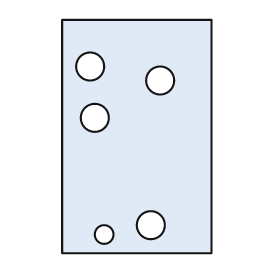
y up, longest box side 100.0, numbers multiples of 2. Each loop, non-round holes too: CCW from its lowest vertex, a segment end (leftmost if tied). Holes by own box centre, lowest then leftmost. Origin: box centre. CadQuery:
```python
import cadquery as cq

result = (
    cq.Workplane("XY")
    .moveTo(-32.0, -50.0)
    .lineTo(32.0, -50.0)
    .lineTo(32.0, 50.0)
    .lineTo(-32.0, 50.0)
    .close()
    .moveTo(-14.0, -42.0)
    .circle(4.0)
    .moveTo(6.0, -38.0)
    .circle(6.0)
    .moveTo(-18.0, 8.0)
    .circle(6.0)
    .moveTo(10.0, 24.0)
    .circle(6.0)
    .moveTo(-20.0, 30.0)
    .circle(6.0)
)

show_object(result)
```